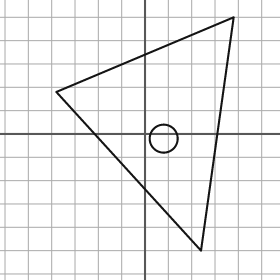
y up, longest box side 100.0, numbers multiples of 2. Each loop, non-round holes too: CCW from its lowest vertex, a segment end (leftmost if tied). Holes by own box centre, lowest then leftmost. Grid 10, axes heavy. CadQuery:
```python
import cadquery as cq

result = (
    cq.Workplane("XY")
    .moveTo(24.0, -50.0)
    .lineTo(38.0, 50.0)
    .lineTo(-38.0, 18.0)
    .close()
    .moveTo(8.0, -2.0)
    .circle(6.0)
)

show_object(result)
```